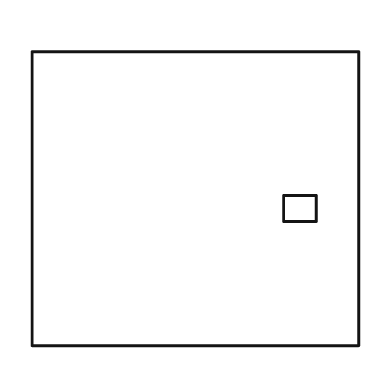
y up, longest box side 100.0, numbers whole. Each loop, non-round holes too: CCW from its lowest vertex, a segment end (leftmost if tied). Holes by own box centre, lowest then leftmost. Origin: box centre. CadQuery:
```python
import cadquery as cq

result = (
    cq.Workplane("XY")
    .moveTo(-50.0, -45.0)
    .lineTo(50.0, -45.0)
    .lineTo(50.0, 45.0)
    .lineTo(-50.0, 45.0)
    .close()
    .moveTo(27.0, -7.0)
    .lineTo(37.0, -7.0)
    .lineTo(37.0, 1.0)
    .lineTo(27.0, 1.0)
    .close()
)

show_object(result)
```